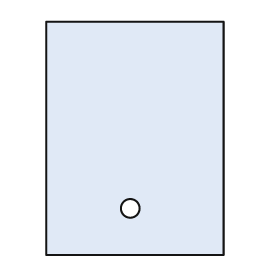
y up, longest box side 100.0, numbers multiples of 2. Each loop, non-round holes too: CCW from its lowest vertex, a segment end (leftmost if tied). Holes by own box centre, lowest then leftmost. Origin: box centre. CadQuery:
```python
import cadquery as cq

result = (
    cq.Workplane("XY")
    .moveTo(-38.0, -50.0)
    .lineTo(38.0, -50.0)
    .lineTo(38.0, 50.0)
    .lineTo(-38.0, 50.0)
    .close()
    .moveTo(-2.0, -30.0)
    .circle(4.0)
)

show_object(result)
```